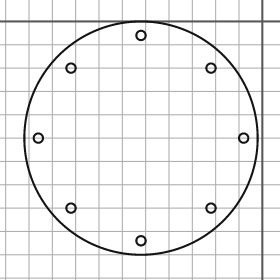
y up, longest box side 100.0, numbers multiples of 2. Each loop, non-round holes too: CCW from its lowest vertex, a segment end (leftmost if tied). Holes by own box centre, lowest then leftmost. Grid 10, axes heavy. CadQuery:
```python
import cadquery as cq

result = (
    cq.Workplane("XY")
    .moveTo(-52.0, -50.0)
    .circle(50.0)
    .moveTo(-52.0, -94.0)
    .circle(2.0)
    .moveTo(-82.0, -80.0)
    .circle(2.0)
    .moveTo(-22.0, -80.0)
    .circle(2.0)
    .moveTo(-96.0, -50.0)
    .circle(2.0)
    .moveTo(-8.0, -50.0)
    .circle(2.0)
    .moveTo(-82.0, -20.0)
    .circle(2.0)
    .moveTo(-22.0, -20.0)
    .circle(2.0)
    .moveTo(-52.0, -6.0)
    .circle(2.0)
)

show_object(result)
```